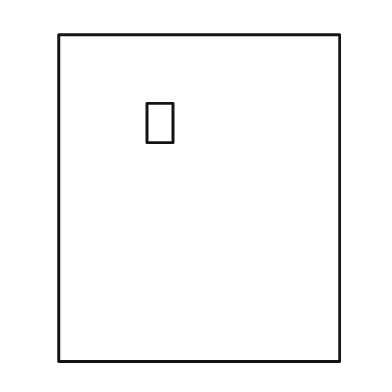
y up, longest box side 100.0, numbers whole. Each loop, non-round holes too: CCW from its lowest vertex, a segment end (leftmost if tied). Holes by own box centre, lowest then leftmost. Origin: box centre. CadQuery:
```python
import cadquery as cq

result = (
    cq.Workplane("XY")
    .moveTo(-43.0, -50.0)
    .lineTo(43.0, -50.0)
    .lineTo(43.0, 50.0)
    .lineTo(-43.0, 50.0)
    .close()
    .moveTo(-16.0, 17.0)
    .lineTo(-8.0, 17.0)
    .lineTo(-8.0, 29.0)
    .lineTo(-16.0, 29.0)
    .close()
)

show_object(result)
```